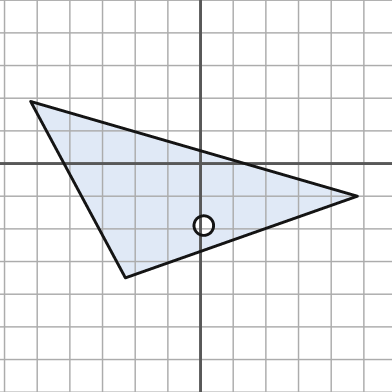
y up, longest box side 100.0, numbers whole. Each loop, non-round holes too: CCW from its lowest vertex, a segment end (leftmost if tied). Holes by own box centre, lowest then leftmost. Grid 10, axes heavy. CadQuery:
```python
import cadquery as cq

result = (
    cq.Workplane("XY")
    .moveTo(-23.0, -35.0)
    .lineTo(48.0, -10.0)
    .lineTo(-52.0, 19.0)
    .close()
    .moveTo(1.0, -19.0)
    .circle(3.0)
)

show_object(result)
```